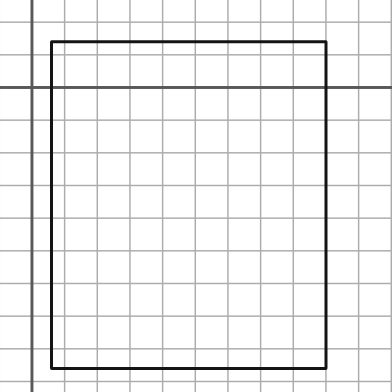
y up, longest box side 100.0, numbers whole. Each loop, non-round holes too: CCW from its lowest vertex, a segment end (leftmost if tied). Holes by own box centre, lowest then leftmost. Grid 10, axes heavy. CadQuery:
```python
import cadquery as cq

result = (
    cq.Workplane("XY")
    .moveTo(6.0, -86.0)
    .lineTo(90.0, -86.0)
    .lineTo(90.0, 14.0)
    .lineTo(6.0, 14.0)
    .close()
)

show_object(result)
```